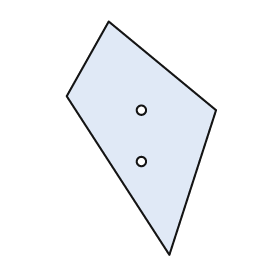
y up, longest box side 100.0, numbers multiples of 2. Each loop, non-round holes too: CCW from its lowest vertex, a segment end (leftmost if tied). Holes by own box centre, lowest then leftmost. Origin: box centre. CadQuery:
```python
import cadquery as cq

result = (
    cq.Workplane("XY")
    .moveTo(12.0, -50.0)
    .lineTo(32.0, 12.0)
    .lineTo(-14.0, 50.0)
    .lineTo(-32.0, 18.0)
    .close()
    .moveTo(0.0, -10.0)
    .circle(2.0)
    .moveTo(0.0, 12.0)
    .circle(2.0)
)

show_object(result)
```